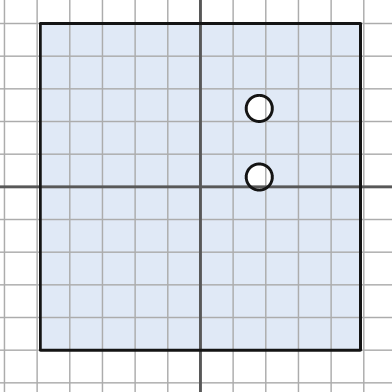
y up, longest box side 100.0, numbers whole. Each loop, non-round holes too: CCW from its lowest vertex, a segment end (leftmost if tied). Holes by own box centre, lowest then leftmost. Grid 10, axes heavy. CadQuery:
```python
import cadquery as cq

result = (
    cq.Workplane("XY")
    .moveTo(-49.0, -50.0)
    .lineTo(49.0, -50.0)
    .lineTo(49.0, 50.0)
    .lineTo(-49.0, 50.0)
    .close()
    .moveTo(18.0, 3.0)
    .circle(4.0)
    .moveTo(18.0, 24.0)
    .circle(4.0)
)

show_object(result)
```